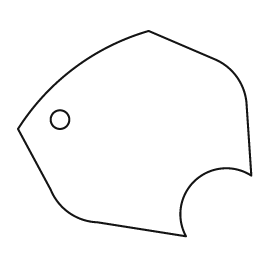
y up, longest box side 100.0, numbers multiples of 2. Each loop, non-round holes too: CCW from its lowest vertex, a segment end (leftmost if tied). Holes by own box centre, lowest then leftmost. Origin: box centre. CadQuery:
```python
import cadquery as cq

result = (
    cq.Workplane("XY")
    .moveTo(22.0, -44.0)
    .threePointArc((26.0, -20.0), (50.0, -18.0))
    .lineTo(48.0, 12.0)
    .threePointArc((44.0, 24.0), (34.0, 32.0))
    .lineTo(6.0, 44.0)
    .threePointArc((-26.0, 28.0), (-50.0, 2.0))
    .lineTo(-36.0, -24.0)
    .threePointArc((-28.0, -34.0), (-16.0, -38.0))
    .close()
    .moveTo(-32.0, 6.0)
    .circle(4.0)
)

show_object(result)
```